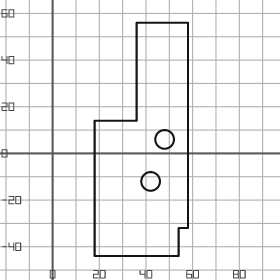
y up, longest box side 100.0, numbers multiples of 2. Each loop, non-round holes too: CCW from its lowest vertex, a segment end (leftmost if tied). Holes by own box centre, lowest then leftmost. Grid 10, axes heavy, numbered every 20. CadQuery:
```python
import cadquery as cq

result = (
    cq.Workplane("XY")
    .moveTo(18.0, -44.0)
    .lineTo(54.0, -44.0)
    .lineTo(54.0, -32.0)
    .lineTo(58.0, -32.0)
    .lineTo(58.0, 56.0)
    .lineTo(36.0, 56.0)
    .lineTo(36.0, 14.0)
    .lineTo(18.0, 14.0)
    .close()
    .moveTo(42.0, -12.0)
    .circle(4.0)
    .moveTo(48.0, 6.0)
    .circle(4.0)
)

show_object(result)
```